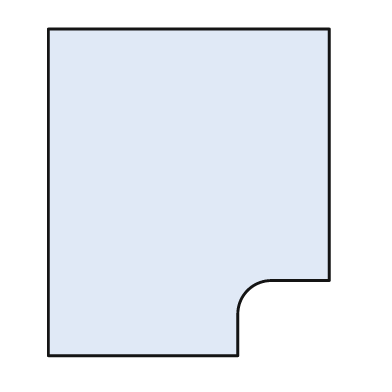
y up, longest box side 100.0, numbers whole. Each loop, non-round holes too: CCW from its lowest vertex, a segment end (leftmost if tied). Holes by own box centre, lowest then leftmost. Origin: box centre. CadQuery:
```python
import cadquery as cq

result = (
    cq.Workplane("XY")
    .moveTo(-43.0, -50.0)
    .lineTo(15.0, -50.0)
    .lineTo(15.0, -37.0)
    .threePointArc((18.0, -30.0), (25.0, -27.0))
    .lineTo(43.0, -27.0)
    .lineTo(43.0, 50.0)
    .lineTo(-43.0, 50.0)
    .close()
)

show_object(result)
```